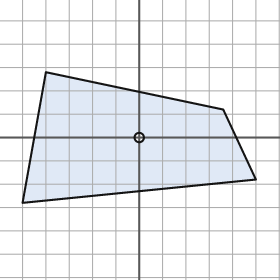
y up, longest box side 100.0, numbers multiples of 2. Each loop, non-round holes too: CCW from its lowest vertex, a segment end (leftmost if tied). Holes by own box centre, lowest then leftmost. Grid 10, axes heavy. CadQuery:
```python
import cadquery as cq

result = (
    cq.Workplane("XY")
    .moveTo(-50.0, -28.0)
    .lineTo(50.0, -18.0)
    .lineTo(36.0, 12.0)
    .lineTo(-40.0, 28.0)
    .close()
    .moveTo(0.0, 0.0)
    .circle(2.0)
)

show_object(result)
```